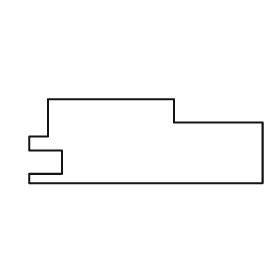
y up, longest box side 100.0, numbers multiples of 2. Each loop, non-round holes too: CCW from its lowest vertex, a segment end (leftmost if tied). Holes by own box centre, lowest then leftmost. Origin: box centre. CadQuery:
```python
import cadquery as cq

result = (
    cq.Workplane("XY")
    .moveTo(-50.0, -18.0)
    .lineTo(50.0, -18.0)
    .lineTo(50.0, 8.0)
    .lineTo(12.0, 8.0)
    .lineTo(12.0, 18.0)
    .lineTo(-42.0, 18.0)
    .lineTo(-42.0, 2.0)
    .lineTo(-50.0, 2.0)
    .lineTo(-50.0, -4.0)
    .lineTo(-36.0, -4.0)
    .lineTo(-36.0, -14.0)
    .lineTo(-50.0, -14.0)
    .close()
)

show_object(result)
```